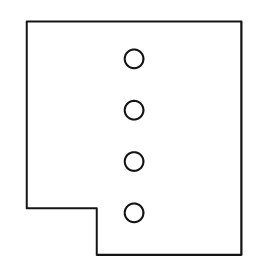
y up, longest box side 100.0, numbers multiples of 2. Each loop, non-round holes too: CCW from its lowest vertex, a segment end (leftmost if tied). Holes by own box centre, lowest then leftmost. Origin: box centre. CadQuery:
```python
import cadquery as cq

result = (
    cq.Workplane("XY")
    .moveTo(-16.0, -50.0)
    .lineTo(46.0, -50.0)
    .lineTo(46.0, 50.0)
    .lineTo(-46.0, 50.0)
    .lineTo(-46.0, -30.0)
    .lineTo(-16.0, -30.0)
    .close()
    .moveTo(0.0, -32.0)
    .circle(4.0)
    .moveTo(0.0, -10.0)
    .circle(4.0)
    .moveTo(0.0, 12.0)
    .circle(4.0)
    .moveTo(0.0, 34.0)
    .circle(4.0)
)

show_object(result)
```